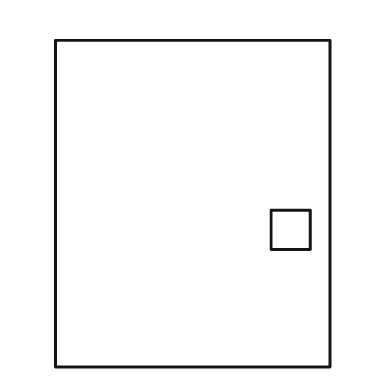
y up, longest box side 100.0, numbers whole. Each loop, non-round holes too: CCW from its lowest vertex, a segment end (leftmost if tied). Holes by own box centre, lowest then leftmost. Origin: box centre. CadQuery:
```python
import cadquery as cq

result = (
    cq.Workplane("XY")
    .moveTo(-42.0, -50.0)
    .lineTo(42.0, -50.0)
    .lineTo(42.0, 50.0)
    .lineTo(-42.0, 50.0)
    .close()
    .moveTo(24.0, -14.0)
    .lineTo(36.0, -14.0)
    .lineTo(36.0, -2.0)
    .lineTo(24.0, -2.0)
    .close()
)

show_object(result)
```